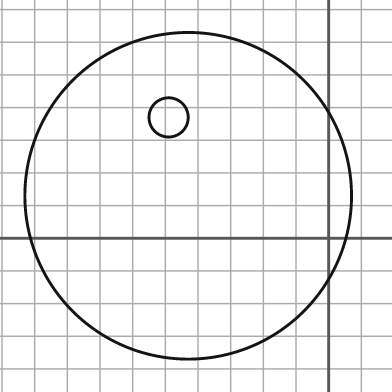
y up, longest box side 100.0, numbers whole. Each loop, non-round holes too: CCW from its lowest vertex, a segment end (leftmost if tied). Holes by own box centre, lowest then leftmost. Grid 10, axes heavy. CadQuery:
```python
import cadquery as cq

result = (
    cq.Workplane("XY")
    .moveTo(-43.0, 13.0)
    .circle(50.0)
    .moveTo(-49.0, 37.0)
    .circle(6.0)
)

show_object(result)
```